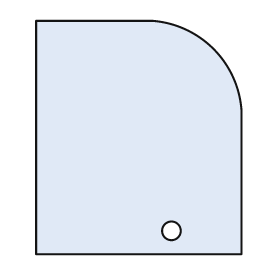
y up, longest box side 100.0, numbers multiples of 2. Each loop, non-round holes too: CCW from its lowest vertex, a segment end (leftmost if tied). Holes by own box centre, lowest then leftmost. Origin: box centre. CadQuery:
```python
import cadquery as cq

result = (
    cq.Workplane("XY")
    .moveTo(-44.0, -50.0)
    .lineTo(44.0, -50.0)
    .lineTo(44.0, 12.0)
    .threePointArc((32.0, 38.0), (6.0, 50.0))
    .lineTo(-44.0, 50.0)
    .close()
    .moveTo(14.0, -40.0)
    .circle(4.0)
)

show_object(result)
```